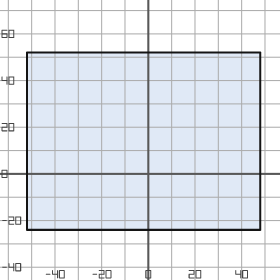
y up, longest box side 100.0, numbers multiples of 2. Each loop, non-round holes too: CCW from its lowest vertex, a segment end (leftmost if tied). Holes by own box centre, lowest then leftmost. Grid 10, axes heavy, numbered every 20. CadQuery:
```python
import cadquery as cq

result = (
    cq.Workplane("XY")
    .moveTo(-52.0, -24.0)
    .lineTo(48.0, -24.0)
    .lineTo(48.0, 52.0)
    .lineTo(-52.0, 52.0)
    .close()
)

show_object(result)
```